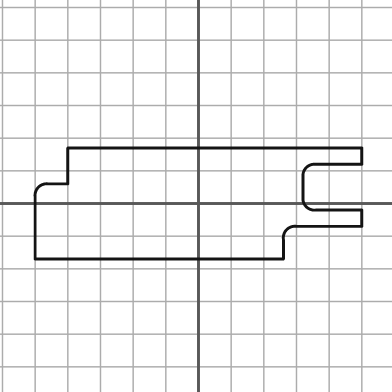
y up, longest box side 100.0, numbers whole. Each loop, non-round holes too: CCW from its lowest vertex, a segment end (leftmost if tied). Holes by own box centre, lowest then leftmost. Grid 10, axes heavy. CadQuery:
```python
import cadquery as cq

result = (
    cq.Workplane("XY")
    .moveTo(-50.0, -17.0)
    .lineTo(26.0, -17.0)
    .lineTo(26.0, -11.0)
    .threePointArc((27.0, -8.0), (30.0, -7.0))
    .lineTo(50.0, -7.0)
    .lineTo(50.0, -2.0)
    .lineTo(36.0, -2.0)
    .threePointArc((33.0, -1.0), (32.0, 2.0))
    .lineTo(32.0, 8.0)
    .threePointArc((33.0, 11.0), (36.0, 12.0))
    .lineTo(50.0, 12.0)
    .lineTo(50.0, 17.0)
    .lineTo(-40.0, 17.0)
    .lineTo(-40.0, 6.0)
    .lineTo(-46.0, 6.0)
    .threePointArc((-49.0, 5.0), (-50.0, 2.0))
    .close()
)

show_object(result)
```